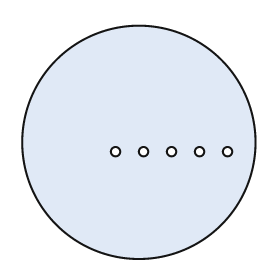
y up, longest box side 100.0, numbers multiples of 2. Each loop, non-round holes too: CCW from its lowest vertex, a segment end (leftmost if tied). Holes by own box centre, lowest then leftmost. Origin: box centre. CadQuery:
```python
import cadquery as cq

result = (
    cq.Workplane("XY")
    .moveTo(0.0, 0.0)
    .circle(50.0)
    .moveTo(-10.0, -4.0)
    .circle(2.0)
    .moveTo(2.0, -4.0)
    .circle(2.0)
    .moveTo(14.0, -4.0)
    .circle(2.0)
    .moveTo(26.0, -4.0)
    .circle(2.0)
    .moveTo(38.0, -4.0)
    .circle(2.0)
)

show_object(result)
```